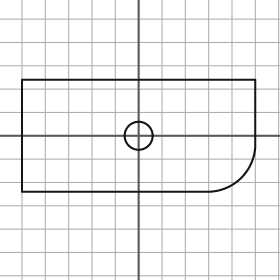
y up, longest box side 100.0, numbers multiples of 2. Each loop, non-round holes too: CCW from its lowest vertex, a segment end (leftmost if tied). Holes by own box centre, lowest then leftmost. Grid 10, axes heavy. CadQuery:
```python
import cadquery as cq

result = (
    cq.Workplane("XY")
    .moveTo(-50.0, -24.0)
    .lineTo(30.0, -24.0)
    .threePointArc((44.0, -18.0), (50.0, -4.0))
    .lineTo(50.0, 24.0)
    .lineTo(-50.0, 24.0)
    .close()
    .moveTo(0.0, 0.0)
    .circle(6.0)
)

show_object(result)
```